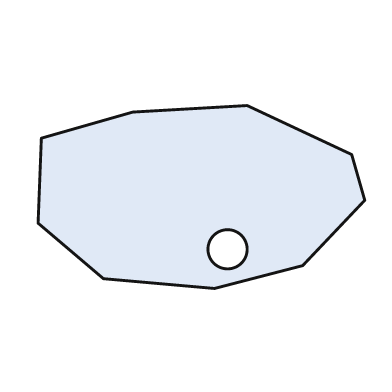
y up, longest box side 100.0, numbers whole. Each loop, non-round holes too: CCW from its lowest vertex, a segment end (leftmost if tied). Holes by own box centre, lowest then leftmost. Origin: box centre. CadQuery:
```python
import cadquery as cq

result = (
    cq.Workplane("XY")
    .moveTo(4.0, -28.0)
    .lineTo(31.0, -21.0)
    .lineTo(50.0, -1.0)
    .lineTo(46.0, 13.0)
    .lineTo(14.0, 28.0)
    .lineTo(-21.0, 26.0)
    .lineTo(-49.0, 18.0)
    .lineTo(-50.0, -8.0)
    .lineTo(-30.0, -25.0)
    .close()
    .moveTo(8.0, -16.0)
    .circle(6.0)
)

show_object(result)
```